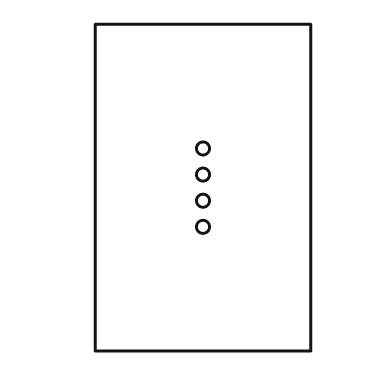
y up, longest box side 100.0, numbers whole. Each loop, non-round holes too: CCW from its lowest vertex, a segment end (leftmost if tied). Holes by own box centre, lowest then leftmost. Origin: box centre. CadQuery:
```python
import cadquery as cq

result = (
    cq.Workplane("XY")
    .moveTo(-33.0, -50.0)
    .lineTo(33.0, -50.0)
    .lineTo(33.0, 50.0)
    .lineTo(-33.0, 50.0)
    .close()
    .moveTo(0.0, -12.0)
    .circle(2.0)
    .moveTo(0.0, -4.0)
    .circle(2.0)
    .moveTo(0.0, 4.0)
    .circle(2.0)
    .moveTo(0.0, 12.0)
    .circle(2.0)
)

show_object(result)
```